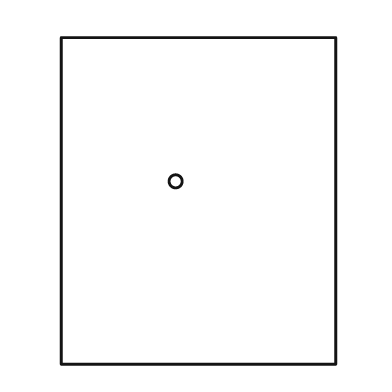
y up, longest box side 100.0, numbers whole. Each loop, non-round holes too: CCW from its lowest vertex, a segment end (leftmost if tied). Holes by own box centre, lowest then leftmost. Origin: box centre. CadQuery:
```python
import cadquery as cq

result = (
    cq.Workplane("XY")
    .moveTo(-42.0, -50.0)
    .lineTo(42.0, -50.0)
    .lineTo(42.0, 50.0)
    .lineTo(-42.0, 50.0)
    .close()
    .moveTo(-7.0, 6.0)
    .circle(2.0)
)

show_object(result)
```